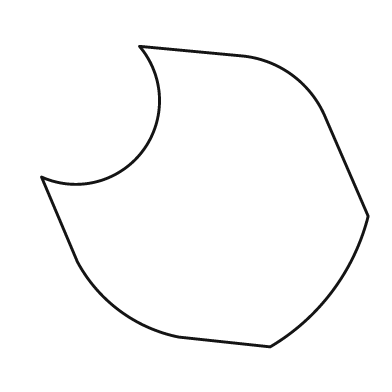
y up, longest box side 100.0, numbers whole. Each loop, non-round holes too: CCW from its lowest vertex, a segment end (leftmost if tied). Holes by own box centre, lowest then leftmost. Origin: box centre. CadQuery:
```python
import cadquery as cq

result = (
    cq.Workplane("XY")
    .moveTo(20.0, -46.0)
    .threePointArc((39.0, -29.0), (50.0, -6.0))
    .lineTo(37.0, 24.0)
    .threePointArc((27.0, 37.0), (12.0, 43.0))
    .lineTo(-20.0, 46.0)
    .threePointArc((-19.0, 14.0), (-50.0, 6.0))
    .lineTo(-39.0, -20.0)
    .threePointArc((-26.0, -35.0), (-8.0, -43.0))
    .close()
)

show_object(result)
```